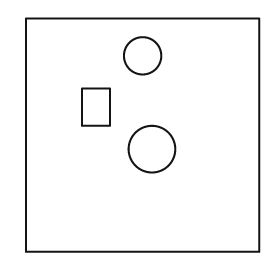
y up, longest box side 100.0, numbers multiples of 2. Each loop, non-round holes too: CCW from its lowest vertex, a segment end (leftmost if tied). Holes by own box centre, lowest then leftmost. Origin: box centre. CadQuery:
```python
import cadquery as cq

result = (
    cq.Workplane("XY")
    .moveTo(-50.0, -50.0)
    .lineTo(50.0, -50.0)
    .lineTo(50.0, 50.0)
    .lineTo(-50.0, 50.0)
    .close()
    .moveTo(4.0, -6.0)
    .circle(10.0)
    .moveTo(-26.0, 4.0)
    .lineTo(-14.0, 4.0)
    .lineTo(-14.0, 20.0)
    .lineTo(-26.0, 20.0)
    .close()
    .moveTo(0.0, 34.0)
    .circle(8.0)
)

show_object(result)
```